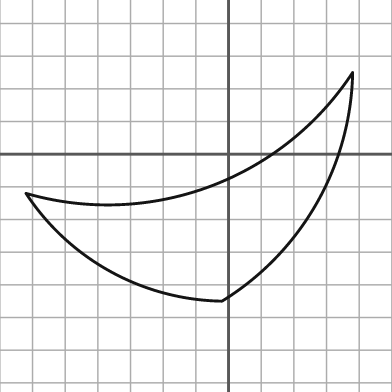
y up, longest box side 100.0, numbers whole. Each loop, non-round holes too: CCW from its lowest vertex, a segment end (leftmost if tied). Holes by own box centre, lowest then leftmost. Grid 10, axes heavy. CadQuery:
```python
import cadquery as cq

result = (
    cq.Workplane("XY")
    .moveTo(-2.0, -45.0)
    .threePointArc((27.0, -15.0), (38.0, 25.0))
    .threePointArc((-6.0, -10.0), (-62.0, -12.0))
    .threePointArc((-36.0, -36.0), (-2.0, -45.0))
    .close()
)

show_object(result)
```